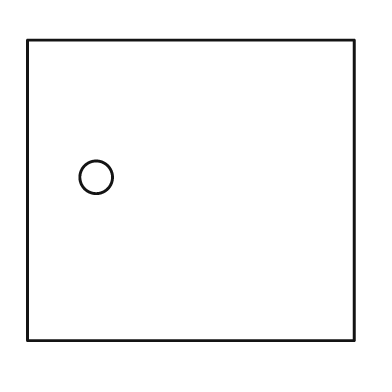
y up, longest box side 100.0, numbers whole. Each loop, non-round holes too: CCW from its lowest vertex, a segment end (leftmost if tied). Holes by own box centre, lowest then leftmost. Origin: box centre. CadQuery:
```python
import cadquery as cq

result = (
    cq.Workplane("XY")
    .moveTo(-50.0, -46.0)
    .lineTo(50.0, -46.0)
    .lineTo(50.0, 46.0)
    .lineTo(-50.0, 46.0)
    .close()
    .moveTo(-29.0, 4.0)
    .circle(5.0)
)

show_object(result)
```